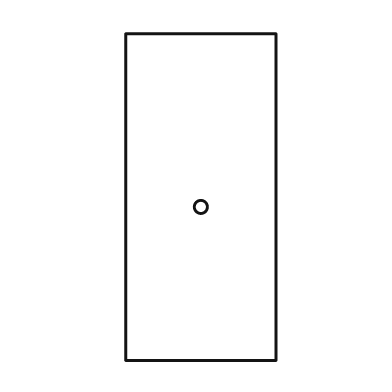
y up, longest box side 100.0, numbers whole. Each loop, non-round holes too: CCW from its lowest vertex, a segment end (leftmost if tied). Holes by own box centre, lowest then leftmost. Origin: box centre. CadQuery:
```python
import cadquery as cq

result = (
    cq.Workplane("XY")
    .moveTo(-23.0, -50.0)
    .lineTo(23.0, -50.0)
    .lineTo(23.0, 50.0)
    .lineTo(-23.0, 50.0)
    .close()
    .moveTo(0.0, -3.0)
    .circle(2.0)
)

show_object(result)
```